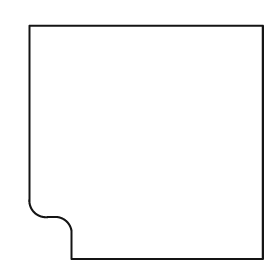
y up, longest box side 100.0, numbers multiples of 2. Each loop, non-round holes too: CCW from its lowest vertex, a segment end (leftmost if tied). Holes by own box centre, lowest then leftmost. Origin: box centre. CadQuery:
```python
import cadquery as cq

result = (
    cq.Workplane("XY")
    .moveTo(-32.0, -50.0)
    .lineTo(50.0, -50.0)
    .lineTo(50.0, 50.0)
    .lineTo(-50.0, 50.0)
    .lineTo(-50.0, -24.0)
    .threePointArc((-48.0, -30.0), (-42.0, -32.0))
    .lineTo(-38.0, -32.0)
    .threePointArc((-34.0, -34.0), (-32.0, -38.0))
    .close()
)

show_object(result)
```